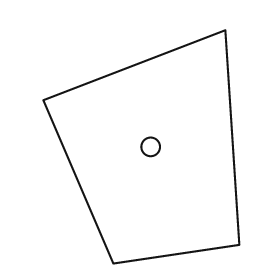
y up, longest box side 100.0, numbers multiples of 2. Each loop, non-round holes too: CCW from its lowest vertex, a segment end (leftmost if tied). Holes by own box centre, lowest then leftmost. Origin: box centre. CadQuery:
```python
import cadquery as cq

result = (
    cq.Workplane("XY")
    .moveTo(-12.0, -50.0)
    .lineTo(42.0, -42.0)
    .lineTo(36.0, 50.0)
    .lineTo(-42.0, 20.0)
    .close()
    .moveTo(4.0, 0.0)
    .circle(4.0)
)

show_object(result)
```